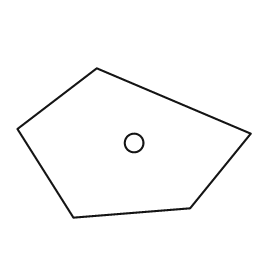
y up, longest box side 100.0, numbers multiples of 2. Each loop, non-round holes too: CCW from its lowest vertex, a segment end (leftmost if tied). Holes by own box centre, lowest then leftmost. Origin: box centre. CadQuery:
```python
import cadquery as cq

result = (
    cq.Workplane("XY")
    .moveTo(-26.0, -32.0)
    .lineTo(24.0, -28.0)
    .lineTo(50.0, 4.0)
    .lineTo(-16.0, 32.0)
    .lineTo(-50.0, 6.0)
    .close()
    .moveTo(0.0, 0.0)
    .circle(4.0)
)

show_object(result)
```